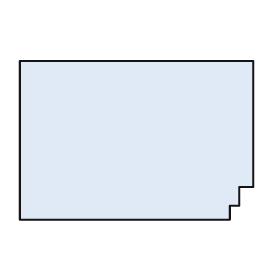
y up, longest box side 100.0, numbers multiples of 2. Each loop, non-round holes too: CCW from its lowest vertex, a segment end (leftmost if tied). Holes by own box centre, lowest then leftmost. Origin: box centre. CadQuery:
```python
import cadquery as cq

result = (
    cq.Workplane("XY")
    .moveTo(-50.0, -34.0)
    .lineTo(40.0, -34.0)
    .lineTo(40.0, -28.0)
    .lineTo(44.0, -28.0)
    .lineTo(44.0, -20.0)
    .lineTo(50.0, -20.0)
    .lineTo(50.0, 34.0)
    .lineTo(-50.0, 34.0)
    .close()
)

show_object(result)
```